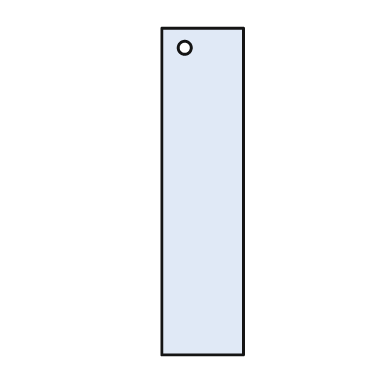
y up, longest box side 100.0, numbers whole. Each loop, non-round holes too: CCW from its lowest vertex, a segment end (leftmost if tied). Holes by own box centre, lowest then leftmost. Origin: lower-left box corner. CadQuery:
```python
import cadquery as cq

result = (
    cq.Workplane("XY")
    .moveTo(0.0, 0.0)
    .lineTo(25.0, 0.0)
    .lineTo(25.0, 100.0)
    .lineTo(0.0, 100.0)
    .close()
    .moveTo(7.0, 94.0)
    .circle(2.0)
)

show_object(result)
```